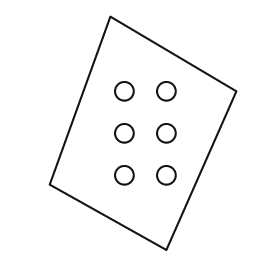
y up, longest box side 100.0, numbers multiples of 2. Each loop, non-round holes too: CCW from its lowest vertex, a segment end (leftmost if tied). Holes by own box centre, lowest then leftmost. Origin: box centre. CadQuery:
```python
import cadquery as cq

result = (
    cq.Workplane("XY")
    .moveTo(10.0, -50.0)
    .lineTo(40.0, 18.0)
    .lineTo(-14.0, 50.0)
    .lineTo(-40.0, -22.0)
    .close()
    .moveTo(-8.0, -18.0)
    .circle(4.0)
    .moveTo(10.0, -18.0)
    .circle(4.0)
    .moveTo(-8.0, 0.0)
    .circle(4.0)
    .moveTo(10.0, 0.0)
    .circle(4.0)
    .moveTo(-8.0, 18.0)
    .circle(4.0)
    .moveTo(10.0, 18.0)
    .circle(4.0)
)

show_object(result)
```